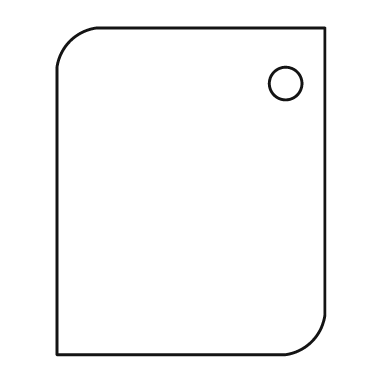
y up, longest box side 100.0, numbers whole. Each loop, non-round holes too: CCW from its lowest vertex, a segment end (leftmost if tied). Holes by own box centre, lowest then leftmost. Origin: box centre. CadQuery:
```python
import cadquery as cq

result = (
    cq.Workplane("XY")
    .moveTo(-41.0, -50.0)
    .lineTo(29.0, -50.0)
    .threePointArc((37.0, -46.0), (41.0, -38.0))
    .lineTo(41.0, 50.0)
    .lineTo(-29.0, 50.0)
    .threePointArc((-37.0, 46.0), (-41.0, 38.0))
    .close()
    .moveTo(29.0, 33.0)
    .circle(5.0)
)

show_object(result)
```